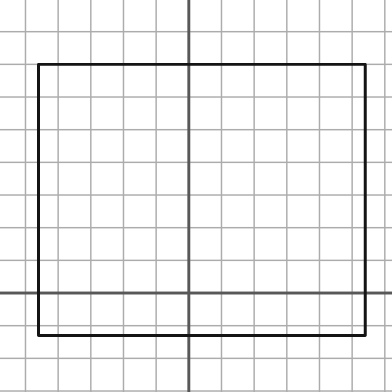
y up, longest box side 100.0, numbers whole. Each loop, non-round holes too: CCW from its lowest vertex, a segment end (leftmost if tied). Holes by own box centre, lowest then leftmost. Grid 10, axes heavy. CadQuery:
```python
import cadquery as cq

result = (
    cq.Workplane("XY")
    .moveTo(-46.0, -13.0)
    .lineTo(54.0, -13.0)
    .lineTo(54.0, 70.0)
    .lineTo(-46.0, 70.0)
    .close()
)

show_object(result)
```